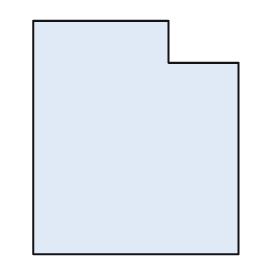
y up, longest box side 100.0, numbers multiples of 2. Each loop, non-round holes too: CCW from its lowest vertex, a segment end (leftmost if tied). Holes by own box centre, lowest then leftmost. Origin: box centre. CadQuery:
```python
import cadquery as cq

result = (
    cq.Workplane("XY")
    .moveTo(-44.0, -50.0)
    .lineTo(44.0, -50.0)
    .lineTo(44.0, 32.0)
    .lineTo(14.0, 32.0)
    .lineTo(14.0, 50.0)
    .lineTo(-44.0, 50.0)
    .close()
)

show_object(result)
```